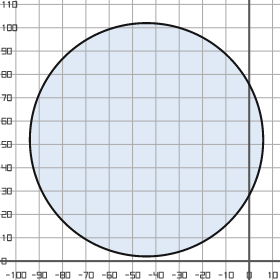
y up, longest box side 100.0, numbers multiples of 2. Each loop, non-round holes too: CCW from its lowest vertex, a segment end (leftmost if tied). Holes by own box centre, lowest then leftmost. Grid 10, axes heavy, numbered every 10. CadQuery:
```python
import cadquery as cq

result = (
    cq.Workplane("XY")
    .moveTo(-44.0, 52.0)
    .circle(50.0)
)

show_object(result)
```